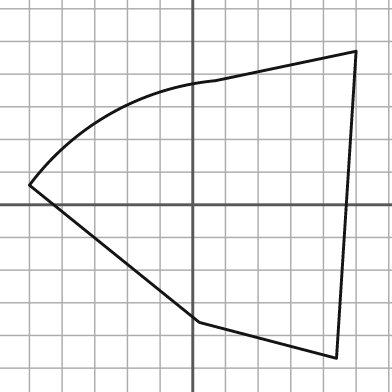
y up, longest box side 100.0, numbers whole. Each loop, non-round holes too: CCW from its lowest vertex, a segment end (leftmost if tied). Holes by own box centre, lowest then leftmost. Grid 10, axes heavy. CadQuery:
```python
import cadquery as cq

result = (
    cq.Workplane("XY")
    .moveTo(44.0, -47.0)
    .lineTo(50.0, 47.0)
    .lineTo(7.0, 38.0)
    .threePointArc((-25.0, 28.0), (-50.0, 6.0))
    .lineTo(2.0, -36.0)
    .close()
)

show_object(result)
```